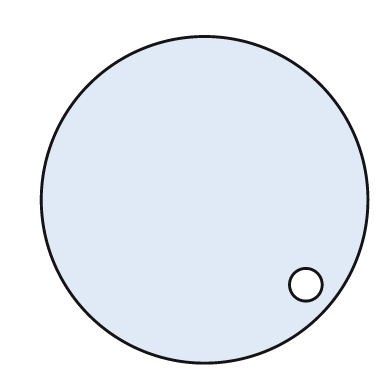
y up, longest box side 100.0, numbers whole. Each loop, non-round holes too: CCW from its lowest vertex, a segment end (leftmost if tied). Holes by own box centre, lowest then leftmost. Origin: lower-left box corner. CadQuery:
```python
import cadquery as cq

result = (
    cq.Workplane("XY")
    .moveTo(50.0, 50.0)
    .circle(50.0)
    .moveTo(81.0, 24.0)
    .circle(5.0)
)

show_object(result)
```